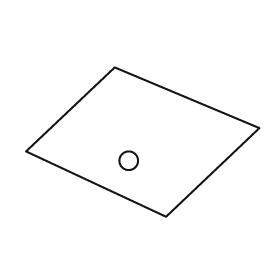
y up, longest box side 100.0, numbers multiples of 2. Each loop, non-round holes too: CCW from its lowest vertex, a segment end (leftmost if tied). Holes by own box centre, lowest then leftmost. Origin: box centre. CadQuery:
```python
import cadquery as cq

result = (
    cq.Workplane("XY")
    .moveTo(10.0, -32.0)
    .lineTo(50.0, 6.0)
    .lineTo(-12.0, 32.0)
    .lineTo(-50.0, -4.0)
    .close()
    .moveTo(-6.0, -8.0)
    .circle(4.0)
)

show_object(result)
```